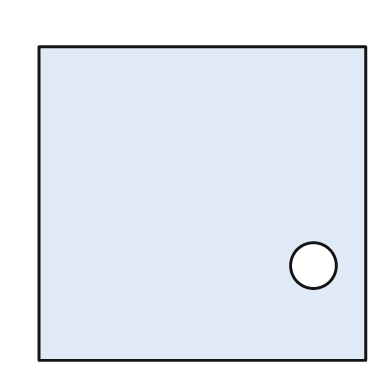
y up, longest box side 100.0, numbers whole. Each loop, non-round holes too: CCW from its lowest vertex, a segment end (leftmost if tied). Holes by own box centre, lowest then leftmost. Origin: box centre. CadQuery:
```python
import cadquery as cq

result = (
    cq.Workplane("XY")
    .moveTo(-50.0, -48.0)
    .lineTo(50.0, -48.0)
    .lineTo(50.0, 48.0)
    .lineTo(-50.0, 48.0)
    .close()
    .moveTo(34.0, -19.0)
    .circle(7.0)
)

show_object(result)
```